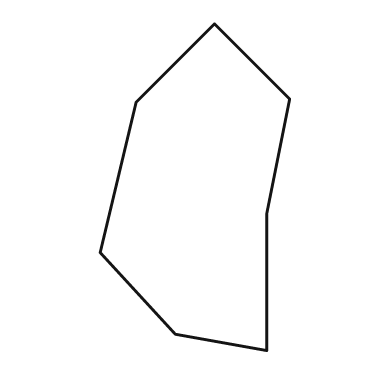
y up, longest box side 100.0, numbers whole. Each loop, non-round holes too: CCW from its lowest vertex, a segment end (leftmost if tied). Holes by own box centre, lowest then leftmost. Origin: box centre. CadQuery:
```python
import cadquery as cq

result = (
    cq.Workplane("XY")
    .moveTo(22.0, -50.0)
    .lineTo(22.0, -8.0)
    .lineTo(29.0, 27.0)
    .lineTo(6.0, 50.0)
    .lineTo(-18.0, 26.0)
    .lineTo(-29.0, -20.0)
    .lineTo(-6.0, -45.0)
    .close()
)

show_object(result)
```